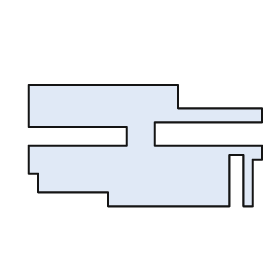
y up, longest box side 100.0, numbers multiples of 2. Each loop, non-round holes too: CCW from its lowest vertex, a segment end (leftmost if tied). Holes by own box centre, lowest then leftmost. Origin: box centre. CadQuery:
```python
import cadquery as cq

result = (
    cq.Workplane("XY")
    .moveTo(-16.0, -26.0)
    .lineTo(36.0, -26.0)
    .lineTo(36.0, -4.0)
    .lineTo(42.0, -4.0)
    .lineTo(42.0, -26.0)
    .lineTo(46.0, -26.0)
    .lineTo(46.0, -6.0)
    .lineTo(50.0, -6.0)
    .lineTo(50.0, 0.0)
    .lineTo(4.0, 0.0)
    .lineTo(4.0, 10.0)
    .lineTo(50.0, 10.0)
    .lineTo(50.0, 16.0)
    .lineTo(14.0, 16.0)
    .lineTo(14.0, 26.0)
    .lineTo(-50.0, 26.0)
    .lineTo(-50.0, 8.0)
    .lineTo(-8.0, 8.0)
    .lineTo(-8.0, 0.0)
    .lineTo(-50.0, 0.0)
    .lineTo(-50.0, -12.0)
    .lineTo(-46.0, -12.0)
    .lineTo(-46.0, -20.0)
    .lineTo(-16.0, -20.0)
    .close()
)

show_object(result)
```